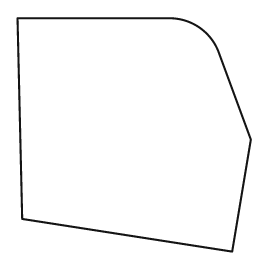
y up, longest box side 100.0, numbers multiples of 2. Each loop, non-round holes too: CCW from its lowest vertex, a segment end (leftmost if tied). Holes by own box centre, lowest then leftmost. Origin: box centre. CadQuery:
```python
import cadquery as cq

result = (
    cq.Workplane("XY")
    .moveTo(42.0, -50.0)
    .lineTo(50.0, -2.0)
    .lineTo(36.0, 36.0)
    .threePointArc((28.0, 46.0), (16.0, 50.0))
    .lineTo(-50.0, 50.0)
    .lineTo(-48.0, -36.0)
    .close()
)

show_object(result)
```